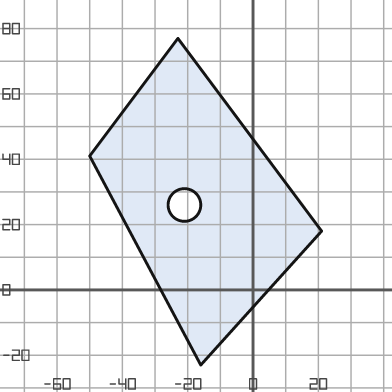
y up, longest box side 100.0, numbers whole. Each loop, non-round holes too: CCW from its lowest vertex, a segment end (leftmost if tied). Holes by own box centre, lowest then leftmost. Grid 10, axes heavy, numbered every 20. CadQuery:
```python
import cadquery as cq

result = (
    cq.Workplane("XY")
    .moveTo(-16.0, -23.0)
    .lineTo(21.0, 18.0)
    .lineTo(-23.0, 77.0)
    .lineTo(-50.0, 41.0)
    .close()
    .moveTo(-21.0, 26.0)
    .circle(5.0)
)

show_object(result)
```